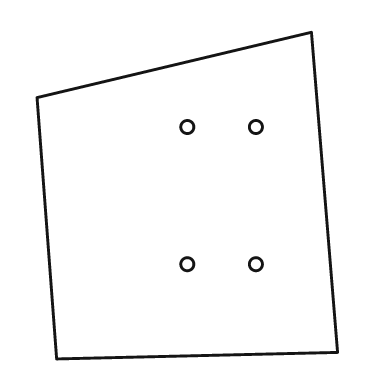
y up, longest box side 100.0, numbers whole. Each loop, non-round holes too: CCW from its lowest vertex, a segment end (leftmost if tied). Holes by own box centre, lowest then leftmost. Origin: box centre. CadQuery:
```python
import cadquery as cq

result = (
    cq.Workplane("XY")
    .moveTo(-40.0, -50.0)
    .lineTo(46.0, -48.0)
    .lineTo(38.0, 50.0)
    .lineTo(-46.0, 30.0)
    .close()
    .moveTo(0.0, -21.0)
    .circle(2.0)
    .moveTo(21.0, -21.0)
    .circle(2.0)
    .moveTo(0.0, 21.0)
    .circle(2.0)
    .moveTo(21.0, 21.0)
    .circle(2.0)
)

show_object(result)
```